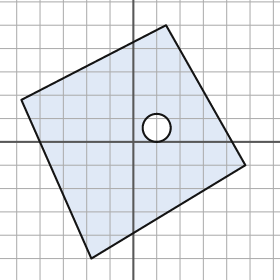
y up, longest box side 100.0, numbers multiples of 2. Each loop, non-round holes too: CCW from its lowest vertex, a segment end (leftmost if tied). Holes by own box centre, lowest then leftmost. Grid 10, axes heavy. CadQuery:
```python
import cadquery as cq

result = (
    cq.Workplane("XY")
    .moveTo(-18.0, -50.0)
    .lineTo(48.0, -10.0)
    .lineTo(14.0, 50.0)
    .lineTo(-48.0, 18.0)
    .close()
    .moveTo(10.0, 6.0)
    .circle(6.0)
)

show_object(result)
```